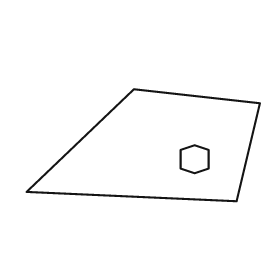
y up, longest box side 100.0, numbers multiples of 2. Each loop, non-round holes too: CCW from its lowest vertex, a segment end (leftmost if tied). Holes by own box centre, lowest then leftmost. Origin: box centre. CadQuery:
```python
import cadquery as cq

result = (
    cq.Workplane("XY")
    .moveTo(40.0, -24.0)
    .lineTo(50.0, 18.0)
    .lineTo(-4.0, 24.0)
    .lineTo(-50.0, -20.0)
    .close()
    .moveTo(22.0, -12.0)
    .lineTo(28.0, -10.0)
    .lineTo(28.0, -2.0)
    .lineTo(22.0, 0.0)
    .lineTo(16.0, -2.0)
    .lineTo(16.0, -10.0)
    .close()
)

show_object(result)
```